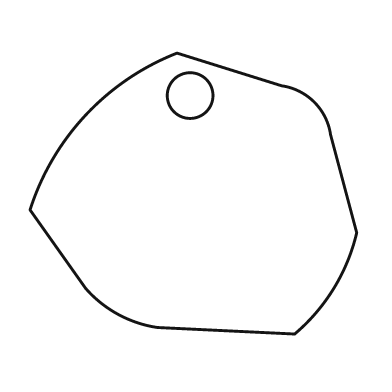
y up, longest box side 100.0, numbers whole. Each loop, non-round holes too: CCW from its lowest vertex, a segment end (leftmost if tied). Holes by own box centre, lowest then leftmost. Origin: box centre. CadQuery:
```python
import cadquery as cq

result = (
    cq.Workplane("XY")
    .moveTo(31.0, -43.0)
    .threePointArc((43.0, -29.0), (50.0, -12.0))
    .lineTo(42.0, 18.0)
    .threePointArc((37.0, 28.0), (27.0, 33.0))
    .lineTo(-5.0, 43.0)
    .threePointArc((-33.0, 24.0), (-50.0, -5.0))
    .lineTo(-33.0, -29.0)
    .threePointArc((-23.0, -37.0), (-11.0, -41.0))
    .close()
    .moveTo(-1.0, 30.0)
    .circle(7.0)
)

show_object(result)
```